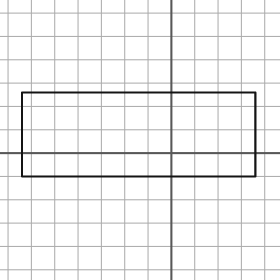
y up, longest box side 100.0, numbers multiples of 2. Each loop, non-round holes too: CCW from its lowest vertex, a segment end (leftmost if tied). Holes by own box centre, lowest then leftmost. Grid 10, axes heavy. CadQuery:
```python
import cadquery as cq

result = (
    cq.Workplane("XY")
    .moveTo(-64.0, -10.0)
    .lineTo(36.0, -10.0)
    .lineTo(36.0, 26.0)
    .lineTo(-64.0, 26.0)
    .close()
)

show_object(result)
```